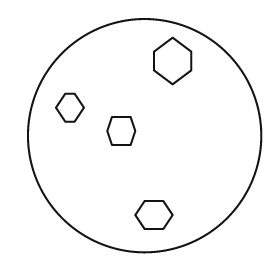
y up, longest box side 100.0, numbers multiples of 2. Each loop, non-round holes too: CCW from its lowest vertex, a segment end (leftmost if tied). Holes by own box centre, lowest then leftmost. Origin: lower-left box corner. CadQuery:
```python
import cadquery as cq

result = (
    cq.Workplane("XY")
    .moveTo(50.0, 50.0)
    .circle(50.0)
    .moveTo(50.0, 10.0)
    .lineTo(58.0, 10.0)
    .lineTo(62.0, 16.0)
    .lineTo(58.0, 22.0)
    .lineTo(50.0, 22.0)
    .lineTo(46.0, 16.0)
    .close()
    .moveTo(36.0, 46.0)
    .lineTo(44.0, 46.0)
    .lineTo(46.0, 52.0)
    .lineTo(44.0, 58.0)
    .lineTo(36.0, 58.0)
    .lineTo(34.0, 52.0)
    .close()
    .moveTo(16.0, 56.0)
    .lineTo(20.0, 56.0)
    .lineTo(24.0, 62.0)
    .lineTo(20.0, 68.0)
    .lineTo(16.0, 68.0)
    .lineTo(12.0, 62.0)
    .close()
    .moveTo(62.0, 72.0)
    .lineTo(70.0, 78.0)
    .lineTo(70.0, 86.0)
    .lineTo(62.0, 92.0)
    .lineTo(54.0, 86.0)
    .lineTo(54.0, 78.0)
    .close()
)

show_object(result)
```